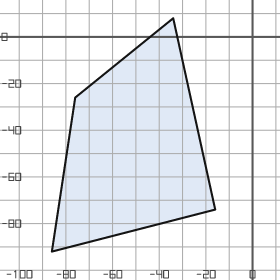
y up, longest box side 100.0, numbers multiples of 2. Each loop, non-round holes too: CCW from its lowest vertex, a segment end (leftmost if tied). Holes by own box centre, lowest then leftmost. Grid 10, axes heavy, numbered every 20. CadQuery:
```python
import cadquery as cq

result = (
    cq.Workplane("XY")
    .moveTo(-86.0, -92.0)
    .lineTo(-16.0, -74.0)
    .lineTo(-34.0, 8.0)
    .lineTo(-76.0, -26.0)
    .close()
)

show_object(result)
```